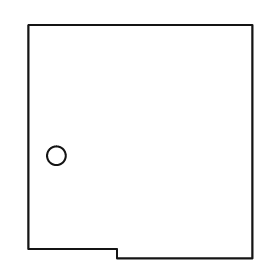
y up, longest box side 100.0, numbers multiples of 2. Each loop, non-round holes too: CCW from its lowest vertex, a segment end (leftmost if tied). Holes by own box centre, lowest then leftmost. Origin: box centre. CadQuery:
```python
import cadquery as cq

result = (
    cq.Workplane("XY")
    .moveTo(-10.0, -50.0)
    .lineTo(48.0, -50.0)
    .lineTo(48.0, 50.0)
    .lineTo(-48.0, 50.0)
    .lineTo(-48.0, -46.0)
    .lineTo(-10.0, -46.0)
    .close()
    .moveTo(-36.0, -6.0)
    .circle(4.0)
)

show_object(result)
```